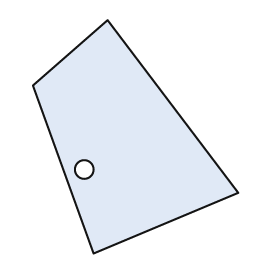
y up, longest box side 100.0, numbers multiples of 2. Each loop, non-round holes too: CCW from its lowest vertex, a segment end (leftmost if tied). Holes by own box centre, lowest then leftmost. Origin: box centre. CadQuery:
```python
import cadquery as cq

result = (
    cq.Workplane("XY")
    .moveTo(-18.0, -50.0)
    .lineTo(44.0, -24.0)
    .lineTo(-12.0, 50.0)
    .lineTo(-44.0, 22.0)
    .close()
    .moveTo(-22.0, -14.0)
    .circle(4.0)
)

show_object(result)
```